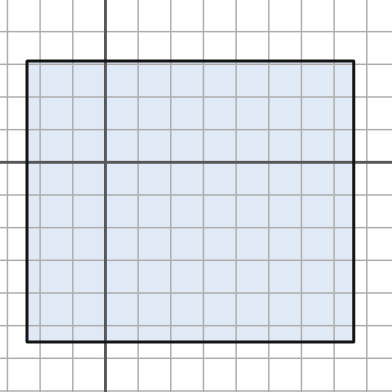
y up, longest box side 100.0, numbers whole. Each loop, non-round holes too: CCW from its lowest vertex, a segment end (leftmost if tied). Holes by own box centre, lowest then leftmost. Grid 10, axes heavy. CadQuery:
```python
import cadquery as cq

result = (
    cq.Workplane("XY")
    .moveTo(-24.0, -55.0)
    .lineTo(76.0, -55.0)
    .lineTo(76.0, 31.0)
    .lineTo(-24.0, 31.0)
    .close()
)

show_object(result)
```